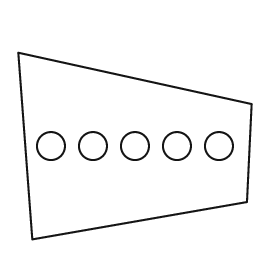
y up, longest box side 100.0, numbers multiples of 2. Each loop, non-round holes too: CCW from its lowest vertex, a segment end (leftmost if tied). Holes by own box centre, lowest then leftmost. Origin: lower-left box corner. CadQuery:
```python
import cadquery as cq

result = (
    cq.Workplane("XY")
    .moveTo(6.0, 0.0)
    .lineTo(98.0, 16.0)
    .lineTo(100.0, 58.0)
    .lineTo(0.0, 80.0)
    .close()
    .moveTo(14.0, 40.0)
    .circle(6.0)
    .moveTo(32.0, 40.0)
    .circle(6.0)
    .moveTo(50.0, 40.0)
    .circle(6.0)
    .moveTo(68.0, 40.0)
    .circle(6.0)
    .moveTo(86.0, 40.0)
    .circle(6.0)
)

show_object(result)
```